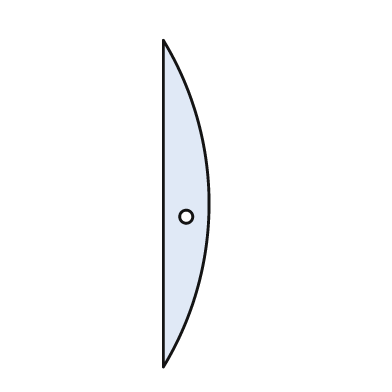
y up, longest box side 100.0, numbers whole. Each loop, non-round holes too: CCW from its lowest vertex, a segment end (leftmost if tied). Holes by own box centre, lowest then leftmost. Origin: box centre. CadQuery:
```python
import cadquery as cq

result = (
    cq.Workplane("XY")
    .moveTo(-7.0, -50.0)
    .threePointArc((7.0, 0.0), (-7.0, 50.0))
    .close()
    .moveTo(0.0, -4.0)
    .circle(2.0)
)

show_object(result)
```